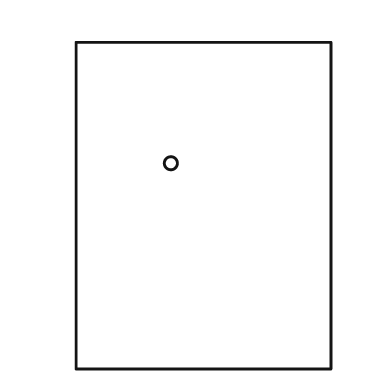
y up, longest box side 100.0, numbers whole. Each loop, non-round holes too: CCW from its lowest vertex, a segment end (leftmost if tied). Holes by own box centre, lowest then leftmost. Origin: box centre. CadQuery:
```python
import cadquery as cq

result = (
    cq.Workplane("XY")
    .moveTo(-39.0, -50.0)
    .lineTo(39.0, -50.0)
    .lineTo(39.0, 50.0)
    .lineTo(-39.0, 50.0)
    .close()
    .moveTo(-10.0, 13.0)
    .circle(2.0)
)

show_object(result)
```